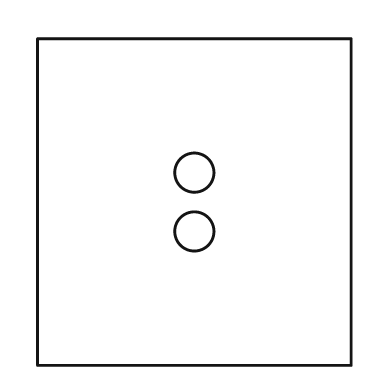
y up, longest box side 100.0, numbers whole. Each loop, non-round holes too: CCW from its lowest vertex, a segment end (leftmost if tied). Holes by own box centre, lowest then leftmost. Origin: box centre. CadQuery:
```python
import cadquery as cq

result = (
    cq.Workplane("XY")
    .moveTo(-48.0, -50.0)
    .lineTo(48.0, -50.0)
    .lineTo(48.0, 50.0)
    .lineTo(-48.0, 50.0)
    .close()
    .moveTo(0.0, -9.0)
    .circle(6.0)
    .moveTo(0.0, 9.0)
    .circle(6.0)
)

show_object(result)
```